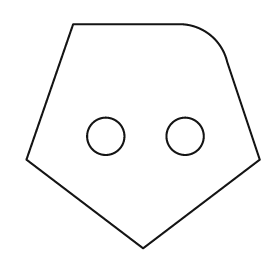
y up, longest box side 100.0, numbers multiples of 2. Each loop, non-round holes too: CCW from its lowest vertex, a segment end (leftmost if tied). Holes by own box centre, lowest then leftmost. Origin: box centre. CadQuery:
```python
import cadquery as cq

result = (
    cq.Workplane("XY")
    .moveTo(0.0, -48.0)
    .lineTo(50.0, -10.0)
    .lineTo(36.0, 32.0)
    .threePointArc((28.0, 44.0), (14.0, 48.0))
    .lineTo(-30.0, 48.0)
    .lineTo(-50.0, -10.0)
    .close()
    .moveTo(-16.0, 0.0)
    .circle(8.0)
    .moveTo(18.0, 0.0)
    .circle(8.0)
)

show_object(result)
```